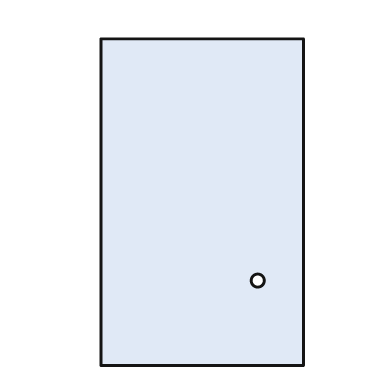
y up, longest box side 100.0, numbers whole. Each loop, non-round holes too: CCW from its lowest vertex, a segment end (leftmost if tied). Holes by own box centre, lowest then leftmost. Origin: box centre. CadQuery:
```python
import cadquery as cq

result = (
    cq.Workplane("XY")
    .moveTo(-31.0, -50.0)
    .lineTo(31.0, -50.0)
    .lineTo(31.0, 50.0)
    .lineTo(-31.0, 50.0)
    .close()
    .moveTo(17.0, -24.0)
    .circle(2.0)
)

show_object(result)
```